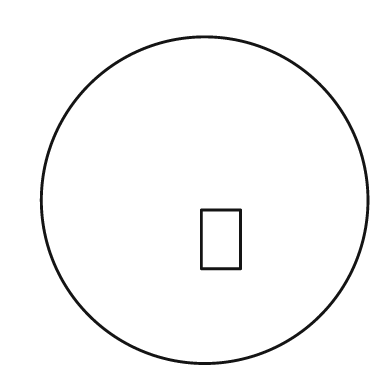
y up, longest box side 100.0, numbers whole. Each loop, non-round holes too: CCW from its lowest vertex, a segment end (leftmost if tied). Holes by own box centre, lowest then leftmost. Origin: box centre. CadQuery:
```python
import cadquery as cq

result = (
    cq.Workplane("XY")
    .moveTo(0.0, 0.0)
    .circle(50.0)
    .moveTo(-1.0, -21.0)
    .lineTo(11.0, -21.0)
    .lineTo(11.0, -3.0)
    .lineTo(-1.0, -3.0)
    .close()
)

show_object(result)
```